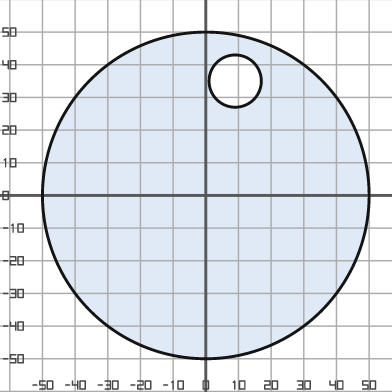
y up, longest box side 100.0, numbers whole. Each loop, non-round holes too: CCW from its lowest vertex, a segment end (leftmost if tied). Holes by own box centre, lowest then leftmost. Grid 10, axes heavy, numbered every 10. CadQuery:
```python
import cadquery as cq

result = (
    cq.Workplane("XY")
    .moveTo(0.0, 0.0)
    .circle(50.0)
    .moveTo(9.0, 35.0)
    .circle(8.0)
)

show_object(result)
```